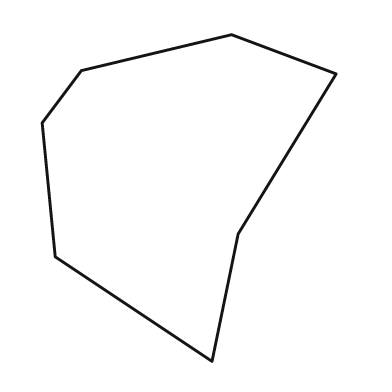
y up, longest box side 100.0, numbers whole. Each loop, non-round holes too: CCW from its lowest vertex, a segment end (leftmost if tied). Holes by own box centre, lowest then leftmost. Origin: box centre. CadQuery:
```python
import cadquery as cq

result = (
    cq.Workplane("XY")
    .moveTo(7.0, -50.0)
    .lineTo(15.0, -11.0)
    .lineTo(45.0, 38.0)
    .lineTo(13.0, 50.0)
    .lineTo(-33.0, 39.0)
    .lineTo(-45.0, 23.0)
    .lineTo(-41.0, -18.0)
    .close()
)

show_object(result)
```